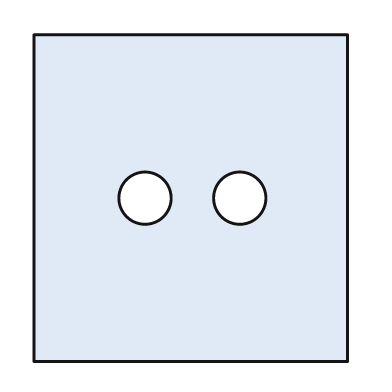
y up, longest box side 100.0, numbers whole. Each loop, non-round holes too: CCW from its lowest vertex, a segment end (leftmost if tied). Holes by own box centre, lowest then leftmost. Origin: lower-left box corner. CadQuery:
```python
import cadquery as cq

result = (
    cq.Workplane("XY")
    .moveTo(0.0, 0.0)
    .lineTo(96.0, 0.0)
    .lineTo(96.0, 100.0)
    .lineTo(0.0, 100.0)
    .close()
    .moveTo(34.0, 50.0)
    .circle(8.0)
    .moveTo(63.0, 50.0)
    .circle(8.0)
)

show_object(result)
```